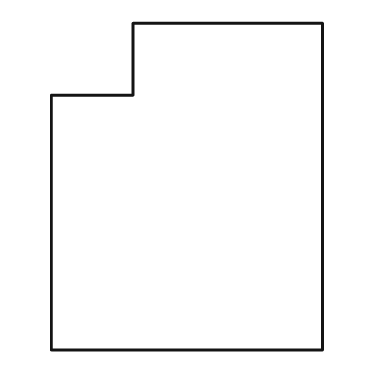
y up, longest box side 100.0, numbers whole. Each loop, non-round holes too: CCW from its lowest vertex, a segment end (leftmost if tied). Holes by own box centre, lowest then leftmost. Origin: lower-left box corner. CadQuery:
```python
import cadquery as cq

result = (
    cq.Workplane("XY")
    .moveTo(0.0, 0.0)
    .lineTo(83.0, 0.0)
    .lineTo(83.0, 100.0)
    .lineTo(25.0, 100.0)
    .lineTo(25.0, 78.0)
    .lineTo(0.0, 78.0)
    .close()
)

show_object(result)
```